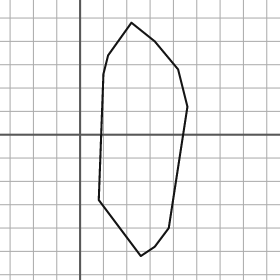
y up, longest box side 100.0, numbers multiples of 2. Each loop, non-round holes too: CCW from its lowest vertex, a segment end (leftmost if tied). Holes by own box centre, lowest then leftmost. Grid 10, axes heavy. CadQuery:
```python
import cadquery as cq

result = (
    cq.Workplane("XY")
    .moveTo(26.0, -52.0)
    .lineTo(32.0, -48.0)
    .lineTo(38.0, -40.0)
    .lineTo(46.0, 12.0)
    .lineTo(42.0, 28.0)
    .lineTo(32.0, 40.0)
    .lineTo(22.0, 48.0)
    .lineTo(12.0, 34.0)
    .lineTo(10.0, 26.0)
    .lineTo(8.0, -28.0)
    .close()
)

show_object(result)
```